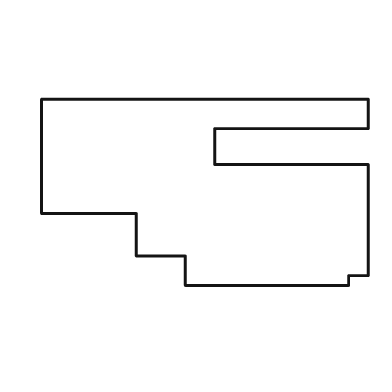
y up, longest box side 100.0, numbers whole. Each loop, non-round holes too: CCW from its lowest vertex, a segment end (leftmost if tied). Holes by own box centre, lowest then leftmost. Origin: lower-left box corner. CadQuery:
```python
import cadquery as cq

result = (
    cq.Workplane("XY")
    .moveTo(44.0, 0.0)
    .lineTo(94.0, 0.0)
    .lineTo(94.0, 3.0)
    .lineTo(100.0, 3.0)
    .lineTo(100.0, 37.0)
    .lineTo(53.0, 37.0)
    .lineTo(53.0, 48.0)
    .lineTo(100.0, 48.0)
    .lineTo(100.0, 57.0)
    .lineTo(0.0, 57.0)
    .lineTo(0.0, 22.0)
    .lineTo(29.0, 22.0)
    .lineTo(29.0, 9.0)
    .lineTo(44.0, 9.0)
    .close()
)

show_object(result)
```